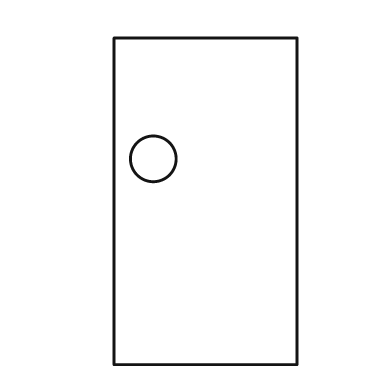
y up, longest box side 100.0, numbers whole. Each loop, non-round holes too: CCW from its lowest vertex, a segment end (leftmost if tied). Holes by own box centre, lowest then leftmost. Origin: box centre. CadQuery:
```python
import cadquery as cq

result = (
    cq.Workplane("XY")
    .moveTo(-28.0, -50.0)
    .lineTo(28.0, -50.0)
    .lineTo(28.0, 50.0)
    .lineTo(-28.0, 50.0)
    .close()
    .moveTo(-16.0, 13.0)
    .circle(7.0)
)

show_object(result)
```